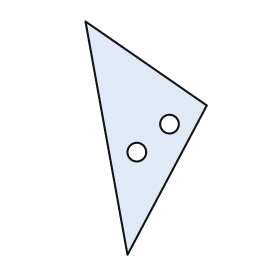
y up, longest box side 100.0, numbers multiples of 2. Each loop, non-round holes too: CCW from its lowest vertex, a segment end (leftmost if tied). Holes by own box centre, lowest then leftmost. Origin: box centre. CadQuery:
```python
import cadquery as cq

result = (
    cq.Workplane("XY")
    .moveTo(-8.0, -50.0)
    .lineTo(26.0, 14.0)
    .lineTo(-26.0, 50.0)
    .close()
    .moveTo(-4.0, -6.0)
    .circle(4.0)
    .moveTo(10.0, 6.0)
    .circle(4.0)
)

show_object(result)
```